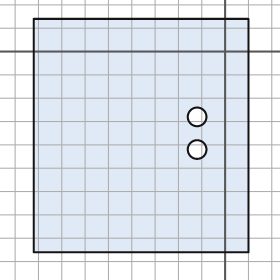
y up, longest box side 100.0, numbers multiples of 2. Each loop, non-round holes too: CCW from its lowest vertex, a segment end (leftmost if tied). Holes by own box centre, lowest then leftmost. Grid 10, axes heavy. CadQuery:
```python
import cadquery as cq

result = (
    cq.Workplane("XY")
    .moveTo(-82.0, -86.0)
    .lineTo(10.0, -86.0)
    .lineTo(10.0, 14.0)
    .lineTo(-82.0, 14.0)
    .close()
    .moveTo(-12.0, -42.0)
    .circle(4.0)
    .moveTo(-12.0, -28.0)
    .circle(4.0)
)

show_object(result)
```